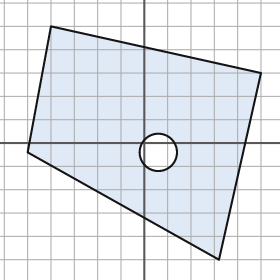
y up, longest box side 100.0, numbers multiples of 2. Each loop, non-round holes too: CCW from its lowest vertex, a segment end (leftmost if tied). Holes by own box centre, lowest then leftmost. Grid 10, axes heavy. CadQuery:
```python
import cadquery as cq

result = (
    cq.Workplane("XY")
    .moveTo(32.0, -50.0)
    .lineTo(50.0, 30.0)
    .lineTo(-40.0, 50.0)
    .lineTo(-50.0, -4.0)
    .close()
    .moveTo(6.0, -4.0)
    .circle(8.0)
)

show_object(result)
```